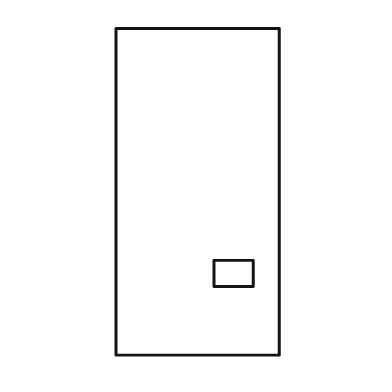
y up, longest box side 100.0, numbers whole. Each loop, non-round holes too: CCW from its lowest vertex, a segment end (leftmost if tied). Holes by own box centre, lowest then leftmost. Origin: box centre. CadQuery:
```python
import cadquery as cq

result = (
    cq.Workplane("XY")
    .moveTo(-25.0, -50.0)
    .lineTo(25.0, -50.0)
    .lineTo(25.0, 50.0)
    .lineTo(-25.0, 50.0)
    .close()
    .moveTo(5.0, -29.0)
    .lineTo(17.0, -29.0)
    .lineTo(17.0, -21.0)
    .lineTo(5.0, -21.0)
    .close()
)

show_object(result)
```